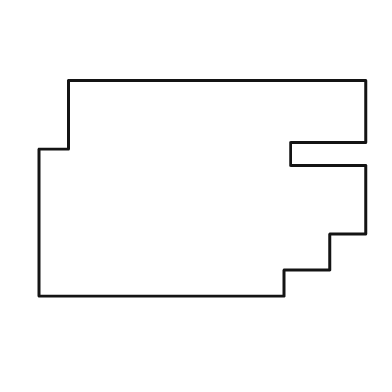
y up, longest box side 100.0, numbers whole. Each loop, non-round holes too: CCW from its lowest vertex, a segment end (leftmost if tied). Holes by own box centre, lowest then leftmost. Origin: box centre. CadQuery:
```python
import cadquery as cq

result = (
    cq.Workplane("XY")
    .moveTo(-50.0, -33.0)
    .lineTo(25.0, -33.0)
    .lineTo(25.0, -25.0)
    .lineTo(39.0, -25.0)
    .lineTo(39.0, -14.0)
    .lineTo(50.0, -14.0)
    .lineTo(50.0, 7.0)
    .lineTo(27.0, 7.0)
    .lineTo(27.0, 14.0)
    .lineTo(50.0, 14.0)
    .lineTo(50.0, 33.0)
    .lineTo(-41.0, 33.0)
    .lineTo(-41.0, 12.0)
    .lineTo(-50.0, 12.0)
    .close()
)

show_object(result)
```